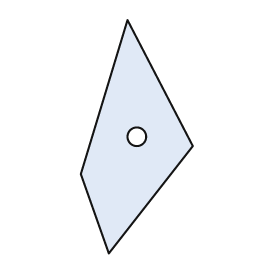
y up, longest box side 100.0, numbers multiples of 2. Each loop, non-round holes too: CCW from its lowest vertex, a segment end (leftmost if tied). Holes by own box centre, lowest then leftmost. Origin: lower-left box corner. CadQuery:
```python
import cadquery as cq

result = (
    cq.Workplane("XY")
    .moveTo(12.0, 0.0)
    .lineTo(48.0, 46.0)
    .lineTo(20.0, 100.0)
    .lineTo(0.0, 34.0)
    .close()
    .moveTo(24.0, 50.0)
    .circle(4.0)
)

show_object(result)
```